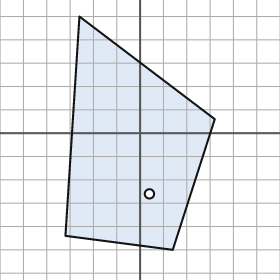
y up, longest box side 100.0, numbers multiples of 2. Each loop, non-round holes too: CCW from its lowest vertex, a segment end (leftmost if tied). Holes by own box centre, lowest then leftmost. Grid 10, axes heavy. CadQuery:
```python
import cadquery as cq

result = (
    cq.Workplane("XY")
    .moveTo(14.0, -50.0)
    .lineTo(32.0, 6.0)
    .lineTo(-26.0, 50.0)
    .lineTo(-32.0, -44.0)
    .close()
    .moveTo(4.0, -26.0)
    .circle(2.0)
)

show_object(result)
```